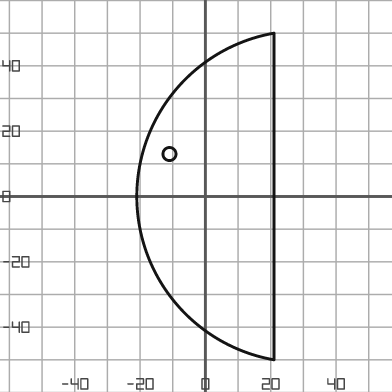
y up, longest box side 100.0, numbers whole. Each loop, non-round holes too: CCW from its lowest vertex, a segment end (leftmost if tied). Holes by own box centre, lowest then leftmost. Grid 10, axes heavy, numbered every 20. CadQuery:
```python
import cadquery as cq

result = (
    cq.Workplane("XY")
    .moveTo(21.0, -50.0)
    .lineTo(21.0, 50.0)
    .threePointArc((-21.0, 0.0), (21.0, -50.0))
    .close()
    .moveTo(-11.0, 13.0)
    .circle(2.0)
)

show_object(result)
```